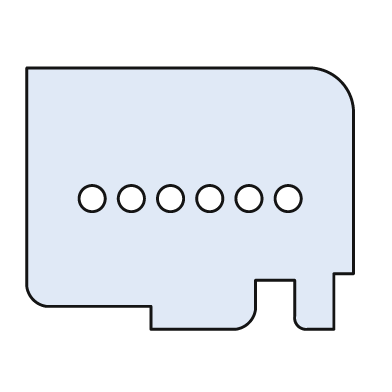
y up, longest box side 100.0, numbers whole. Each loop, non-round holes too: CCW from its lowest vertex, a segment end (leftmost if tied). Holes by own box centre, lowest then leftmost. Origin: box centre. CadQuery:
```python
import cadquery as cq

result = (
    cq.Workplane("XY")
    .moveTo(-12.0, -40.0)
    .lineTo(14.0, -40.0)
    .threePointArc((18.0, -38.0), (20.0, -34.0))
    .lineTo(20.0, -25.0)
    .lineTo(32.0, -25.0)
    .lineTo(32.0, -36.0)
    .threePointArc((33.0, -39.0), (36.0, -40.0))
    .lineTo(44.0, -40.0)
    .lineTo(44.0, -23.0)
    .lineTo(50.0, -23.0)
    .lineTo(50.0, 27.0)
    .threePointArc((46.0, 36.0), (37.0, 40.0))
    .lineTo(-50.0, 40.0)
    .lineTo(-50.0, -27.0)
    .threePointArc((-48.0, -31.0), (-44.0, -33.0))
    .lineTo(-12.0, -33.0)
    .close()
    .moveTo(-30.0, 0.0)
    .circle(4.0)
    .moveTo(-18.0, 0.0)
    .circle(4.0)
    .moveTo(-6.0, 0.0)
    .circle(4.0)
    .moveTo(6.0, 0.0)
    .circle(4.0)
    .moveTo(18.0, 0.0)
    .circle(4.0)
    .moveTo(30.0, 0.0)
    .circle(4.0)
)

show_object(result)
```